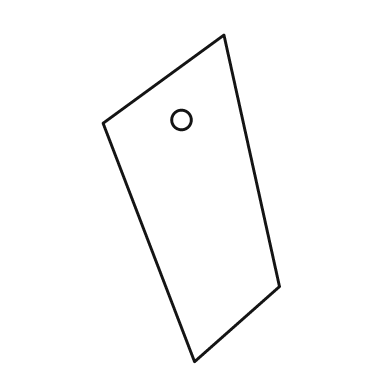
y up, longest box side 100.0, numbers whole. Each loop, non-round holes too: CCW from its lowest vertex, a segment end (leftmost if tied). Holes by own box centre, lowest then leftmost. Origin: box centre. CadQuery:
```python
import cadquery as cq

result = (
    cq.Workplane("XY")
    .moveTo(1.0, -50.0)
    .lineTo(27.0, -27.0)
    .lineTo(10.0, 50.0)
    .lineTo(-27.0, 23.0)
    .close()
    .moveTo(-3.0, 24.0)
    .circle(3.0)
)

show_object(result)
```